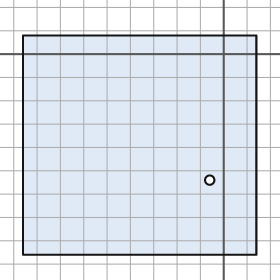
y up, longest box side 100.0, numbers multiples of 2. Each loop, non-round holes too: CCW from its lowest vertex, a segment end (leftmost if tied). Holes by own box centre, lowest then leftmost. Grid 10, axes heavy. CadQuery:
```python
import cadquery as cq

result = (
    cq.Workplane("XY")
    .moveTo(-86.0, -86.0)
    .lineTo(14.0, -86.0)
    .lineTo(14.0, 8.0)
    .lineTo(-86.0, 8.0)
    .close()
    .moveTo(-6.0, -54.0)
    .circle(2.0)
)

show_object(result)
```